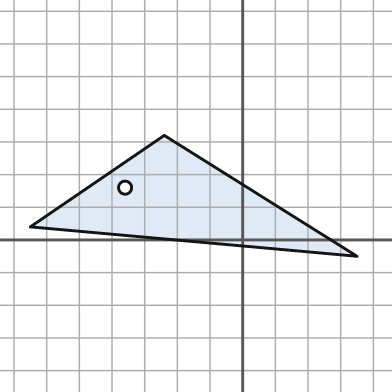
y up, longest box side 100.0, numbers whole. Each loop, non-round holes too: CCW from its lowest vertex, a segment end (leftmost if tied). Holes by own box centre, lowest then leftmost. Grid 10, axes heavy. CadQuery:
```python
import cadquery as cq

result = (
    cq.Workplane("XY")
    .moveTo(35.0, -5.0)
    .lineTo(-24.0, 32.0)
    .lineTo(-65.0, 4.0)
    .close()
    .moveTo(-36.0, 16.0)
    .circle(2.0)
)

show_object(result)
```